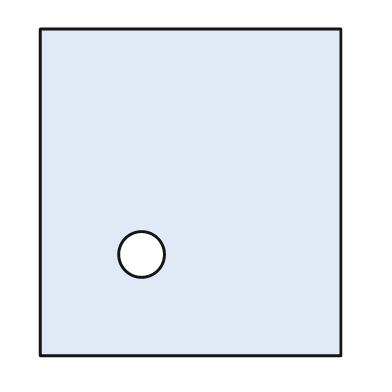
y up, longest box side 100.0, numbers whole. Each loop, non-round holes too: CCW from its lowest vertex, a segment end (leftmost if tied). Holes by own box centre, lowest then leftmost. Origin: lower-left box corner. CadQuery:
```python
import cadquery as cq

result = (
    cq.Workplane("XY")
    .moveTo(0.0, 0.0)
    .lineTo(92.0, 0.0)
    .lineTo(92.0, 100.0)
    .lineTo(0.0, 100.0)
    .close()
    .moveTo(31.0, 31.0)
    .circle(7.0)
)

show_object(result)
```